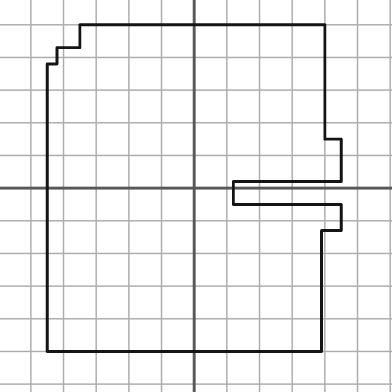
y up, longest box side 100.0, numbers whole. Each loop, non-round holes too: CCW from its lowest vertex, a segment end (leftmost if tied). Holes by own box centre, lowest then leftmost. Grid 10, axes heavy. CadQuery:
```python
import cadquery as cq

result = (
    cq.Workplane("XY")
    .moveTo(-45.0, -50.0)
    .lineTo(39.0, -50.0)
    .lineTo(39.0, -13.0)
    .lineTo(45.0, -13.0)
    .lineTo(45.0, -5.0)
    .lineTo(12.0, -5.0)
    .lineTo(12.0, 2.0)
    .lineTo(45.0, 2.0)
    .lineTo(45.0, 15.0)
    .lineTo(40.0, 15.0)
    .lineTo(40.0, 50.0)
    .lineTo(-35.0, 50.0)
    .lineTo(-35.0, 43.0)
    .lineTo(-42.0, 43.0)
    .lineTo(-42.0, 38.0)
    .lineTo(-45.0, 38.0)
    .close()
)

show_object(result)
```